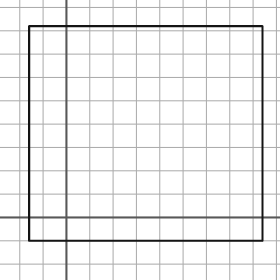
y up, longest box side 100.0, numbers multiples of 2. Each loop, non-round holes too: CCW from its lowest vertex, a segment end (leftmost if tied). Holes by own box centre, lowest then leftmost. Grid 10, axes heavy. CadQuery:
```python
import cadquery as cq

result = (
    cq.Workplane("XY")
    .moveTo(-16.0, -10.0)
    .lineTo(84.0, -10.0)
    .lineTo(84.0, 82.0)
    .lineTo(-16.0, 82.0)
    .close()
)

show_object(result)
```